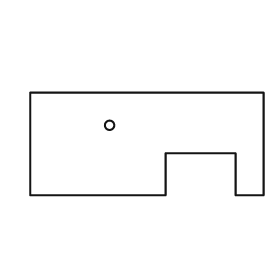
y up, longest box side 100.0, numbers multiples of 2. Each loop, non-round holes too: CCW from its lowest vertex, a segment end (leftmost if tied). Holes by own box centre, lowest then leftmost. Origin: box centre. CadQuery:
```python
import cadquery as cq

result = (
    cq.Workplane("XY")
    .moveTo(-50.0, -22.0)
    .lineTo(8.0, -22.0)
    .lineTo(8.0, -4.0)
    .lineTo(38.0, -4.0)
    .lineTo(38.0, -22.0)
    .lineTo(50.0, -22.0)
    .lineTo(50.0, 22.0)
    .lineTo(-50.0, 22.0)
    .close()
    .moveTo(-16.0, 8.0)
    .circle(2.0)
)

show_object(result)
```